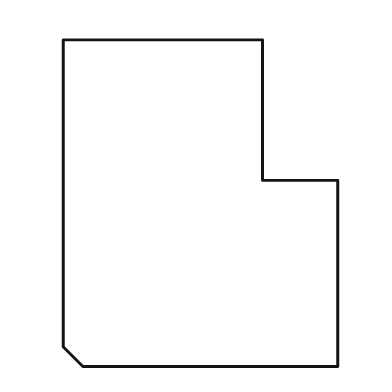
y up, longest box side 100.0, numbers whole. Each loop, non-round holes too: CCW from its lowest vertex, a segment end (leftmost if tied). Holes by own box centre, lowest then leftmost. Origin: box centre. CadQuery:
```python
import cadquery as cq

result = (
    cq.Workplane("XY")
    .moveTo(-36.0, -50.0)
    .lineTo(42.0, -50.0)
    .lineTo(42.0, 7.0)
    .lineTo(19.0, 7.0)
    .lineTo(19.0, 50.0)
    .lineTo(-42.0, 50.0)
    .lineTo(-42.0, -44.0)
    .close()
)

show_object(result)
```